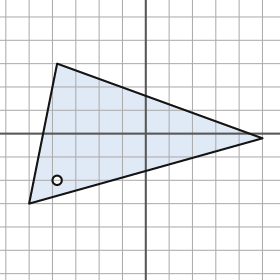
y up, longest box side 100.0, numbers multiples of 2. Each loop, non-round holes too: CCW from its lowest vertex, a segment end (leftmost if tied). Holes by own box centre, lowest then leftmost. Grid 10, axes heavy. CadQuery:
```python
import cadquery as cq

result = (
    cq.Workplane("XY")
    .moveTo(-50.0, -30.0)
    .lineTo(50.0, -2.0)
    .lineTo(-38.0, 30.0)
    .close()
    .moveTo(-38.0, -20.0)
    .circle(2.0)
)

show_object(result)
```